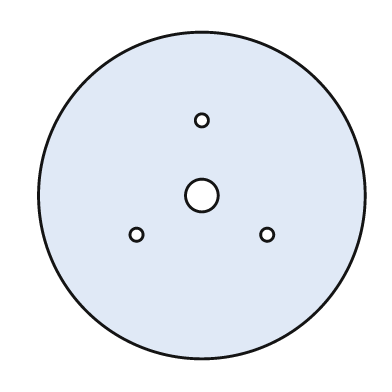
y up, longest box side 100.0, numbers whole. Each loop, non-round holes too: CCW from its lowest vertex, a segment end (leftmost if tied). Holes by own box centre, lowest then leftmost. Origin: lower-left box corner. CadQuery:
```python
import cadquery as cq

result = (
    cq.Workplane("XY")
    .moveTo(50.0, 50.0)
    .circle(50.0)
    .moveTo(30.0, 38.0)
    .circle(2.0)
    .moveTo(70.0, 38.0)
    .circle(2.0)
    .moveTo(50.0, 50.0)
    .circle(5.0)
    .moveTo(50.0, 73.0)
    .circle(2.0)
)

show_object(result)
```